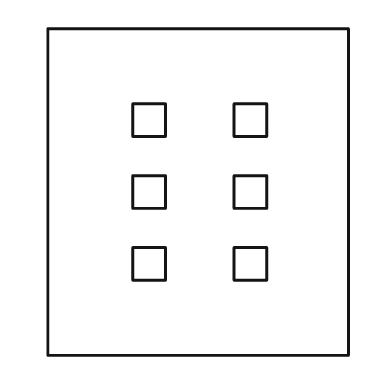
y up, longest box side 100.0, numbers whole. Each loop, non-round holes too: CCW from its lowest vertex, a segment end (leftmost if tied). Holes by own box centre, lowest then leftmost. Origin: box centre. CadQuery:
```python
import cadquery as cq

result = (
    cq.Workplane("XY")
    .moveTo(-46.0, -50.0)
    .lineTo(46.0, -50.0)
    .lineTo(46.0, 50.0)
    .lineTo(-46.0, 50.0)
    .close()
    .moveTo(-20.0, -27.0)
    .lineTo(-10.0, -27.0)
    .lineTo(-10.0, -17.0)
    .lineTo(-20.0, -17.0)
    .close()
    .moveTo(11.0, -27.0)
    .lineTo(21.0, -27.0)
    .lineTo(21.0, -17.0)
    .lineTo(11.0, -17.0)
    .close()
    .moveTo(-20.0, -5.0)
    .lineTo(-10.0, -5.0)
    .lineTo(-10.0, 5.0)
    .lineTo(-20.0, 5.0)
    .close()
    .moveTo(11.0, -5.0)
    .lineTo(21.0, -5.0)
    .lineTo(21.0, 5.0)
    .lineTo(11.0, 5.0)
    .close()
    .moveTo(-20.0, 17.0)
    .lineTo(-10.0, 17.0)
    .lineTo(-10.0, 27.0)
    .lineTo(-20.0, 27.0)
    .close()
    .moveTo(11.0, 17.0)
    .lineTo(21.0, 17.0)
    .lineTo(21.0, 27.0)
    .lineTo(11.0, 27.0)
    .close()
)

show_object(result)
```